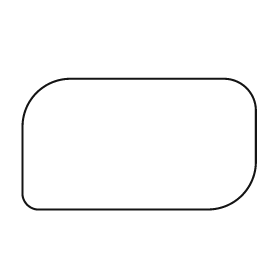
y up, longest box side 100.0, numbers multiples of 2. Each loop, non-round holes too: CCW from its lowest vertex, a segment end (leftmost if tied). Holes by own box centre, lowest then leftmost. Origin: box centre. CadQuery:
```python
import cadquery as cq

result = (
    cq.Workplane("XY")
    .moveTo(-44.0, -28.0)
    .lineTo(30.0, -28.0)
    .threePointArc((44.0, -22.0), (50.0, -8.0))
    .lineTo(50.0, 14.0)
    .threePointArc((46.0, 24.0), (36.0, 28.0))
    .lineTo(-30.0, 28.0)
    .threePointArc((-44.0, 22.0), (-50.0, 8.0))
    .lineTo(-50.0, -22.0)
    .threePointArc((-48.0, -26.0), (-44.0, -28.0))
    .close()
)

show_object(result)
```